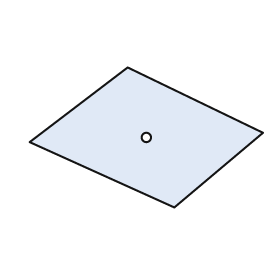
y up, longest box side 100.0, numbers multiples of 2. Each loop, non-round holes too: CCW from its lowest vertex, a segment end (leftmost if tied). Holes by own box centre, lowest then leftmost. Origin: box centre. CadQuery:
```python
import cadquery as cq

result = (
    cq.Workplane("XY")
    .moveTo(12.0, -30.0)
    .lineTo(50.0, 2.0)
    .lineTo(-8.0, 30.0)
    .lineTo(-50.0, -2.0)
    .close()
    .moveTo(0.0, 0.0)
    .circle(2.0)
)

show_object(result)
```